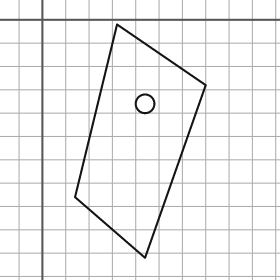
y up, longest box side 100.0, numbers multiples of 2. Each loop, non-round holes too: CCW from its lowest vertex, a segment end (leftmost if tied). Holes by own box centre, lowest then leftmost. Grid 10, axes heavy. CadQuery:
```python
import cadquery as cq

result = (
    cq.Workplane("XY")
    .moveTo(44.0, -102.0)
    .lineTo(70.0, -28.0)
    .lineTo(32.0, -2.0)
    .lineTo(14.0, -76.0)
    .close()
    .moveTo(44.0, -36.0)
    .circle(4.0)
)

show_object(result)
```